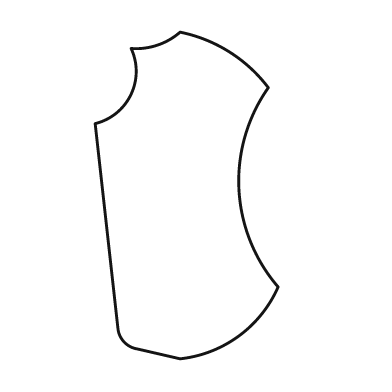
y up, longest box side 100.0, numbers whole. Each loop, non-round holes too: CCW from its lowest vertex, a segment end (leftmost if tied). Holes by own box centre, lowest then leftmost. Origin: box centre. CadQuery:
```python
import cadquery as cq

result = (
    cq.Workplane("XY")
    .moveTo(-2.0, -50.0)
    .threePointArc((16.0, -43.0), (28.0, -28.0))
    .threePointArc((16.0, 2.0), (25.0, 33.0))
    .threePointArc((13.0, 44.0), (-2.0, 50.0))
    .threePointArc((-9.0, 46.0), (-17.0, 45.0))
    .threePointArc((-17.0, 31.0), (-28.0, 22.0))
    .lineTo(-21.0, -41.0)
    .threePointArc((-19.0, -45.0), (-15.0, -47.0))
    .close()
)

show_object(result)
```